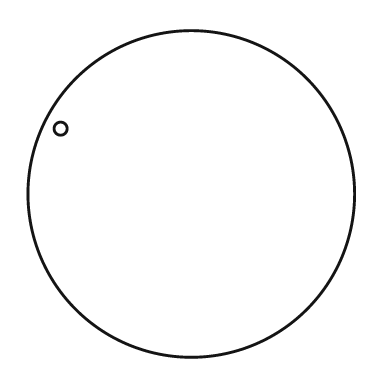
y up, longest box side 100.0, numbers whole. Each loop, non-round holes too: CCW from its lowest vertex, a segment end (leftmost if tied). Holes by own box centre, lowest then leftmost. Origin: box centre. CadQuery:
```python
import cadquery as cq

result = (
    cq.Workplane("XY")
    .moveTo(0.0, 0.0)
    .circle(50.0)
    .moveTo(-40.0, 20.0)
    .circle(2.0)
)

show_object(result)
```